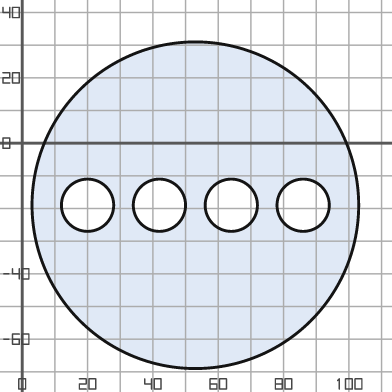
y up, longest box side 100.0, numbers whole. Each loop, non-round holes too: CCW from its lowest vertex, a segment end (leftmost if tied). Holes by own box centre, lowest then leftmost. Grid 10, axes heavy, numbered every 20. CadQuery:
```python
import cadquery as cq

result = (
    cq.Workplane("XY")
    .moveTo(53.0, -19.0)
    .circle(50.0)
    .moveTo(20.0, -19.0)
    .circle(8.0)
    .moveTo(42.0, -19.0)
    .circle(8.0)
    .moveTo(64.0, -19.0)
    .circle(8.0)
    .moveTo(86.0, -19.0)
    .circle(8.0)
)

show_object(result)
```